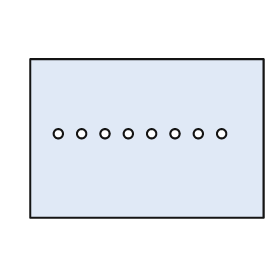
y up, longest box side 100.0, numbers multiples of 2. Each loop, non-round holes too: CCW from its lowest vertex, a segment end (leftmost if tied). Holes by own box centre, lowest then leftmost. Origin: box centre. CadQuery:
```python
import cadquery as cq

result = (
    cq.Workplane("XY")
    .moveTo(-50.0, -34.0)
    .lineTo(50.0, -34.0)
    .lineTo(50.0, 34.0)
    .lineTo(-50.0, 34.0)
    .close()
    .moveTo(-38.0, 2.0)
    .circle(2.0)
    .moveTo(-28.0, 2.0)
    .circle(2.0)
    .moveTo(-18.0, 2.0)
    .circle(2.0)
    .moveTo(-8.0, 2.0)
    .circle(2.0)
    .moveTo(2.0, 2.0)
    .circle(2.0)
    .moveTo(12.0, 2.0)
    .circle(2.0)
    .moveTo(22.0, 2.0)
    .circle(2.0)
    .moveTo(32.0, 2.0)
    .circle(2.0)
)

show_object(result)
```